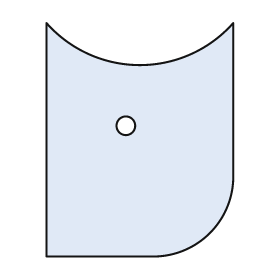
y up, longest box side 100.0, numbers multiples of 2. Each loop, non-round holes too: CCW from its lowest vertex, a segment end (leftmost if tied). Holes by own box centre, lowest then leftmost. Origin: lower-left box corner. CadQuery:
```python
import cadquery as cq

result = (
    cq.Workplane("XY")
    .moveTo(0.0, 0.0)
    .lineTo(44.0, 0.0)
    .threePointArc((70.0, 10.0), (80.0, 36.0))
    .lineTo(80.0, 100.0)
    .threePointArc((40.0, 82.0), (0.0, 100.0))
    .close()
    .moveTo(34.0, 56.0)
    .circle(4.0)
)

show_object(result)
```